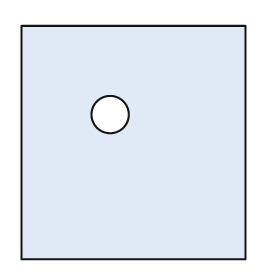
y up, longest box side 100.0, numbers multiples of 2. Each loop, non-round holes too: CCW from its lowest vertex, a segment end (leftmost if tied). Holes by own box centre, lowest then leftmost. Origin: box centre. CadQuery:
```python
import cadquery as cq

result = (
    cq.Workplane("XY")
    .moveTo(-48.0, -50.0)
    .lineTo(48.0, -50.0)
    .lineTo(48.0, 50.0)
    .lineTo(-48.0, 50.0)
    .close()
    .moveTo(-10.0, 12.0)
    .circle(8.0)
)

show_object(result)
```